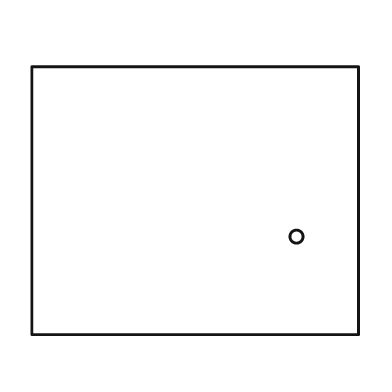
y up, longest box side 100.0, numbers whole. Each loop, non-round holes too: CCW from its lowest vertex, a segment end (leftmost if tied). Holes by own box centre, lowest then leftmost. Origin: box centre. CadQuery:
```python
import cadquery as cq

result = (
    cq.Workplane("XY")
    .moveTo(-50.0, -41.0)
    .lineTo(50.0, -41.0)
    .lineTo(50.0, 41.0)
    .lineTo(-50.0, 41.0)
    .close()
    .moveTo(31.0, -11.0)
    .circle(2.0)
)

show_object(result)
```